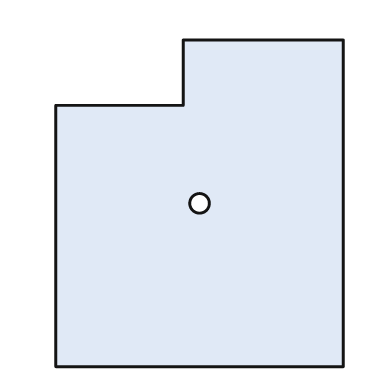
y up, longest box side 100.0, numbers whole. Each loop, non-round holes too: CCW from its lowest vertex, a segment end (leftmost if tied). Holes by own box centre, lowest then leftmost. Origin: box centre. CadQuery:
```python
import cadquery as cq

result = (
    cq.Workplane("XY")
    .moveTo(-44.0, -50.0)
    .lineTo(44.0, -50.0)
    .lineTo(44.0, 50.0)
    .lineTo(-5.0, 50.0)
    .lineTo(-5.0, 30.0)
    .lineTo(-44.0, 30.0)
    .close()
    .moveTo(0.0, 0.0)
    .circle(3.0)
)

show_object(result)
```